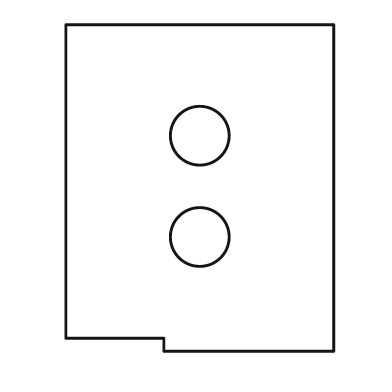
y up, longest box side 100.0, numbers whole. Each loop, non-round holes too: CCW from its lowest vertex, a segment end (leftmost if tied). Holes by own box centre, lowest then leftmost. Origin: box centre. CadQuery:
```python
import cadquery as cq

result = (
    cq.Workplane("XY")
    .moveTo(-11.0, -50.0)
    .lineTo(41.0, -50.0)
    .lineTo(41.0, 50.0)
    .lineTo(-41.0, 50.0)
    .lineTo(-41.0, -46.0)
    .lineTo(-11.0, -46.0)
    .close()
    .moveTo(0.0, -15.0)
    .circle(9.0)
    .moveTo(0.0, 16.0)
    .circle(9.0)
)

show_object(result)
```